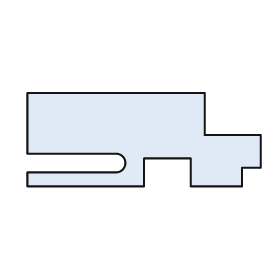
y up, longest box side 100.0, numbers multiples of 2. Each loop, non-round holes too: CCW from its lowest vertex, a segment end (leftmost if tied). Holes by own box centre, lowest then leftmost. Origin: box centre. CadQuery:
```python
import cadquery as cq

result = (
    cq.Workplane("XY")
    .moveTo(-50.0, -20.0)
    .lineTo(0.0, -20.0)
    .lineTo(0.0, -8.0)
    .lineTo(20.0, -8.0)
    .lineTo(20.0, -20.0)
    .lineTo(42.0, -20.0)
    .lineTo(42.0, -12.0)
    .lineTo(50.0, -12.0)
    .lineTo(50.0, 2.0)
    .lineTo(26.0, 2.0)
    .lineTo(26.0, 20.0)
    .lineTo(-50.0, 20.0)
    .lineTo(-50.0, -6.0)
    .lineTo(-12.0, -6.0)
    .threePointArc((-8.0, -10.0), (-12.0, -14.0))
    .lineTo(-50.0, -14.0)
    .close()
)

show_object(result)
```